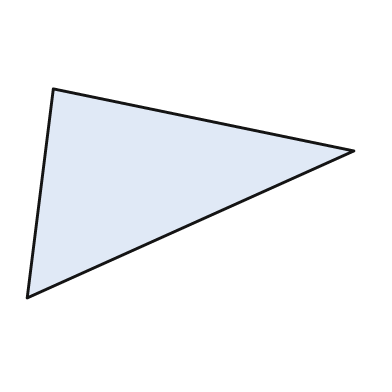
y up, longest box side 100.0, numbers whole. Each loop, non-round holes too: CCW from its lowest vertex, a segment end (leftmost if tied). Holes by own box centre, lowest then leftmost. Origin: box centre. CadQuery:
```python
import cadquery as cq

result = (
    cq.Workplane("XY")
    .moveTo(-50.0, -32.0)
    .lineTo(50.0, 13.0)
    .lineTo(-42.0, 32.0)
    .close()
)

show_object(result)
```